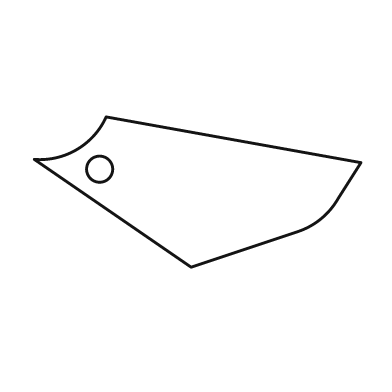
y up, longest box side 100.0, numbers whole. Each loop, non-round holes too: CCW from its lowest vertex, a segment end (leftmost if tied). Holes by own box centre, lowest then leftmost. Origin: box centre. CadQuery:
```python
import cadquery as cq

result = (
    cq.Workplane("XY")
    .moveTo(-2.0, -23.0)
    .lineTo(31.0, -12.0)
    .threePointArc((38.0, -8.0), (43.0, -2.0))
    .lineTo(50.0, 9.0)
    .lineTo(-28.0, 23.0)
    .threePointArc((-37.0, 13.0), (-50.0, 10.0))
    .close()
    .moveTo(-30.0, 7.0)
    .circle(4.0)
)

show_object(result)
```